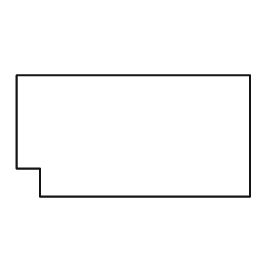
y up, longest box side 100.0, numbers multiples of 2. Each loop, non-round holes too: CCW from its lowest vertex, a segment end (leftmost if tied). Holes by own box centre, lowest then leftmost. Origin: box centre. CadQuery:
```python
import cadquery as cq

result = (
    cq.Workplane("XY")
    .moveTo(-40.0, -26.0)
    .lineTo(50.0, -26.0)
    .lineTo(50.0, 26.0)
    .lineTo(-50.0, 26.0)
    .lineTo(-50.0, -14.0)
    .lineTo(-40.0, -14.0)
    .close()
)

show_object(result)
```